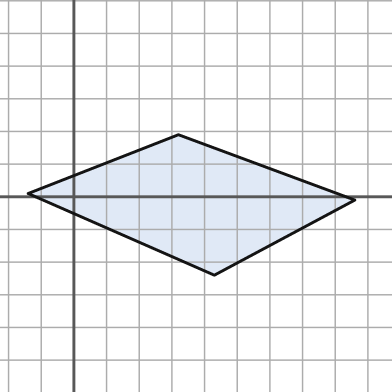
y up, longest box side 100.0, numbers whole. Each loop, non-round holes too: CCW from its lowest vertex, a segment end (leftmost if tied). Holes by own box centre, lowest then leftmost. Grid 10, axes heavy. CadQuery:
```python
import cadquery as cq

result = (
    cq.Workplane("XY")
    .moveTo(43.0, -24.0)
    .lineTo(86.0, -1.0)
    .lineTo(32.0, 19.0)
    .lineTo(-14.0, 1.0)
    .close()
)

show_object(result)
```